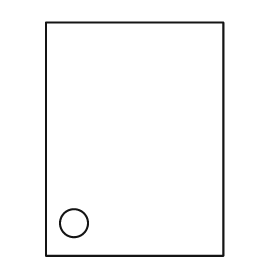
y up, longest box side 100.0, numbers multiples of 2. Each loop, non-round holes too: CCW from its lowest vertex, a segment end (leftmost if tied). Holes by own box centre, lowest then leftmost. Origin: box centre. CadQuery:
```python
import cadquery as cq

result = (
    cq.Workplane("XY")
    .moveTo(-38.0, -50.0)
    .lineTo(38.0, -50.0)
    .lineTo(38.0, 50.0)
    .lineTo(-38.0, 50.0)
    .close()
    .moveTo(-26.0, -36.0)
    .circle(6.0)
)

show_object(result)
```